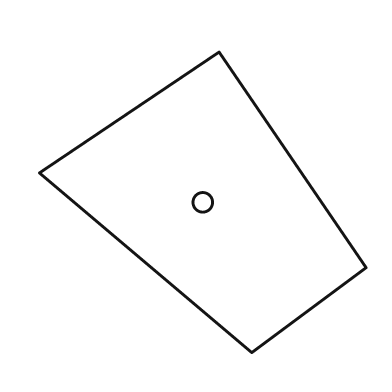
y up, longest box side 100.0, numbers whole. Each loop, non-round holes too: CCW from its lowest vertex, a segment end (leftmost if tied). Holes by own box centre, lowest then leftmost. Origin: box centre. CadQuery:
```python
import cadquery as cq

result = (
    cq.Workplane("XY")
    .moveTo(15.0, -46.0)
    .lineTo(50.0, -20.0)
    .lineTo(5.0, 46.0)
    .lineTo(-50.0, 9.0)
    .close()
    .moveTo(0.0, 0.0)
    .circle(3.0)
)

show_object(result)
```